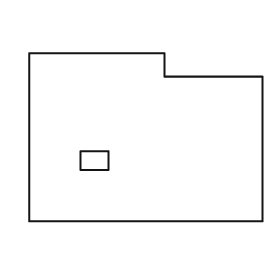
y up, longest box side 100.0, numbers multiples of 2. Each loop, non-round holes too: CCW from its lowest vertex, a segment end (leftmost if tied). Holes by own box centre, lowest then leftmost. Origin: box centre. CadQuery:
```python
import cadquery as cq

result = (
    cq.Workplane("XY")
    .moveTo(-50.0, -36.0)
    .lineTo(50.0, -36.0)
    .lineTo(50.0, 26.0)
    .lineTo(8.0, 26.0)
    .lineTo(8.0, 36.0)
    .lineTo(-50.0, 36.0)
    .close()
    .moveTo(-28.0, -14.0)
    .lineTo(-16.0, -14.0)
    .lineTo(-16.0, -6.0)
    .lineTo(-28.0, -6.0)
    .close()
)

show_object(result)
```